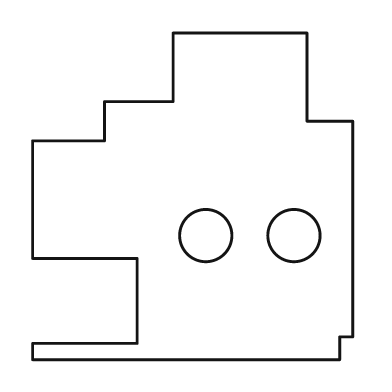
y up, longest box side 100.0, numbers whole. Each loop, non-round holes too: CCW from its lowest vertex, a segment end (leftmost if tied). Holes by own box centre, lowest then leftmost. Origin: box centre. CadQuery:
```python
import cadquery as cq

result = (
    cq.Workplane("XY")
    .moveTo(-49.0, -50.0)
    .lineTo(45.0, -50.0)
    .lineTo(45.0, -43.0)
    .lineTo(49.0, -43.0)
    .lineTo(49.0, 23.0)
    .lineTo(35.0, 23.0)
    .lineTo(35.0, 50.0)
    .lineTo(-6.0, 50.0)
    .lineTo(-6.0, 29.0)
    .lineTo(-27.0, 29.0)
    .lineTo(-27.0, 17.0)
    .lineTo(-49.0, 17.0)
    .lineTo(-49.0, -19.0)
    .lineTo(-17.0, -19.0)
    .lineTo(-17.0, -45.0)
    .lineTo(-49.0, -45.0)
    .close()
    .moveTo(4.0, -12.0)
    .circle(8.0)
    .moveTo(31.0, -12.0)
    .circle(8.0)
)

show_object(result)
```